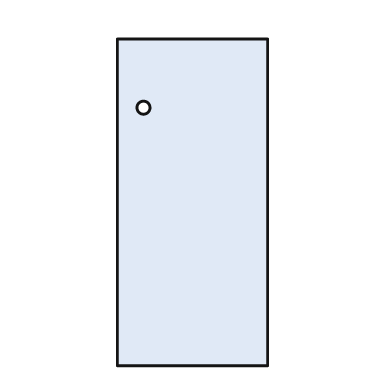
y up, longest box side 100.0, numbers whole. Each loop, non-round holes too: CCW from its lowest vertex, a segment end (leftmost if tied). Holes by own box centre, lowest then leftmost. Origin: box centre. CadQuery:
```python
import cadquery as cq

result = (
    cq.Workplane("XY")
    .moveTo(-23.0, -50.0)
    .lineTo(23.0, -50.0)
    .lineTo(23.0, 50.0)
    .lineTo(-23.0, 50.0)
    .close()
    .moveTo(-15.0, 29.0)
    .circle(2.0)
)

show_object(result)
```